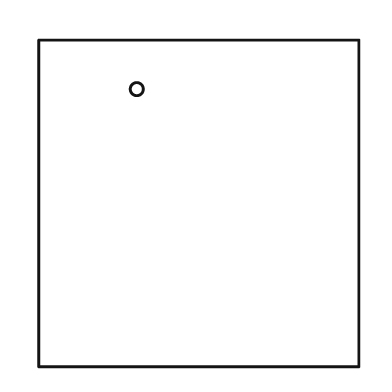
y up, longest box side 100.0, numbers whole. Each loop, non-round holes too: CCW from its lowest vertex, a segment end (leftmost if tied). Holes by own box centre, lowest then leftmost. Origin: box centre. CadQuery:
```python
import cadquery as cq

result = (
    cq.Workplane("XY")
    .moveTo(-49.0, -50.0)
    .lineTo(49.0, -50.0)
    .lineTo(49.0, 50.0)
    .lineTo(-49.0, 50.0)
    .close()
    .moveTo(-19.0, 35.0)
    .circle(2.0)
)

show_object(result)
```